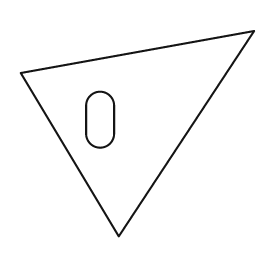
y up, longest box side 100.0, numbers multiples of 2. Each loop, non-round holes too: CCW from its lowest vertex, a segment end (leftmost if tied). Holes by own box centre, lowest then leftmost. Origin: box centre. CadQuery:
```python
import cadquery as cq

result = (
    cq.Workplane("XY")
    .moveTo(-8.0, -44.0)
    .lineTo(50.0, 44.0)
    .lineTo(-50.0, 26.0)
    .close()
    .moveTo(-22.0, 0.0)
    .threePointArc((-16.0, -6.0), (-10.0, 0.0))
    .lineTo(-10.0, 12.0)
    .threePointArc((-16.0, 18.0), (-22.0, 12.0))
    .close()
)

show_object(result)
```